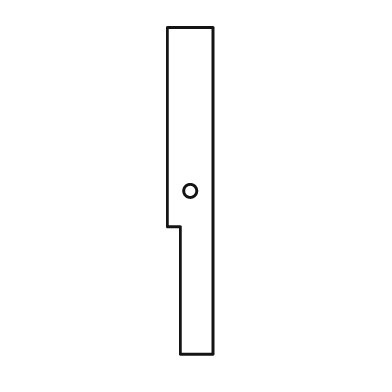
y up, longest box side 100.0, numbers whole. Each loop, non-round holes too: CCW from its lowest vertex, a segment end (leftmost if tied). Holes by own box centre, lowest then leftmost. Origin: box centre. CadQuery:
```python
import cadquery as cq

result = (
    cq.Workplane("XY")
    .moveTo(-3.0, -50.0)
    .lineTo(7.0, -50.0)
    .lineTo(7.0, 50.0)
    .lineTo(-7.0, 50.0)
    .lineTo(-7.0, -11.0)
    .lineTo(-3.0, -11.0)
    .close()
    .moveTo(0.0, 0.0)
    .circle(2.0)
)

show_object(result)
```